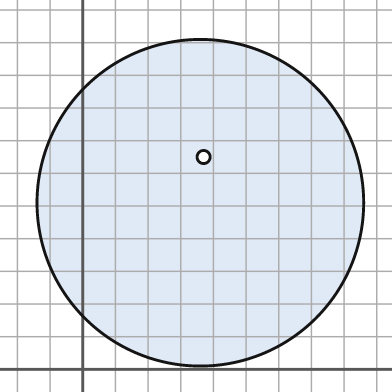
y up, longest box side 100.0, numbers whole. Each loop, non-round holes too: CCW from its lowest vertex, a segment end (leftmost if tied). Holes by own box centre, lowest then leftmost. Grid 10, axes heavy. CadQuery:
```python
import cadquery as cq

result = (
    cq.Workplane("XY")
    .moveTo(36.0, 51.0)
    .circle(50.0)
    .moveTo(37.0, 65.0)
    .circle(2.0)
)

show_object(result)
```